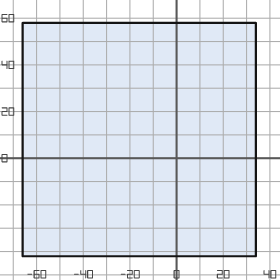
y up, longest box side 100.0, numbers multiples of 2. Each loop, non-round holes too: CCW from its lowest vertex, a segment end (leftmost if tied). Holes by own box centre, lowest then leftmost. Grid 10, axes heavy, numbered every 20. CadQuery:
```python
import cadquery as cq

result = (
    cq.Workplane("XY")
    .moveTo(-66.0, -42.0)
    .lineTo(34.0, -42.0)
    .lineTo(34.0, 58.0)
    .lineTo(-66.0, 58.0)
    .close()
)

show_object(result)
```